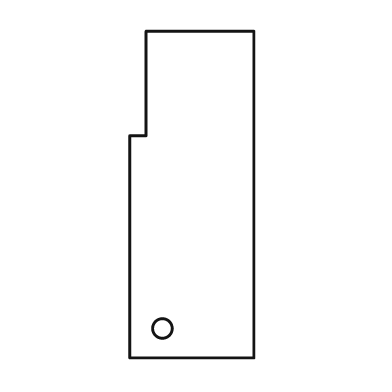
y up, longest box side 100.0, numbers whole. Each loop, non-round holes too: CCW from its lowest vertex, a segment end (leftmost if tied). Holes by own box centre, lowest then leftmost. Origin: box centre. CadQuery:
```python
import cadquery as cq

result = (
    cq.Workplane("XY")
    .moveTo(-19.0, -50.0)
    .lineTo(19.0, -50.0)
    .lineTo(19.0, 50.0)
    .lineTo(-14.0, 50.0)
    .lineTo(-14.0, 18.0)
    .lineTo(-19.0, 18.0)
    .close()
    .moveTo(-9.0, -41.0)
    .circle(3.0)
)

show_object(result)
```